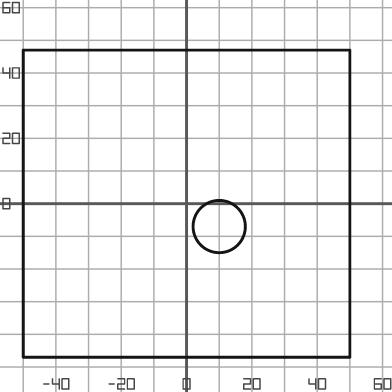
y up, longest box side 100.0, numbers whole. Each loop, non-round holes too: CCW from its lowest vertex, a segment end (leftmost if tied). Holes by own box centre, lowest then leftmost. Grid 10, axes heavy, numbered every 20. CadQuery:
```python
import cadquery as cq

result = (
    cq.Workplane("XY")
    .moveTo(-50.0, -47.0)
    .lineTo(50.0, -47.0)
    .lineTo(50.0, 47.0)
    .lineTo(-50.0, 47.0)
    .close()
    .moveTo(10.0, -7.0)
    .circle(8.0)
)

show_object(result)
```